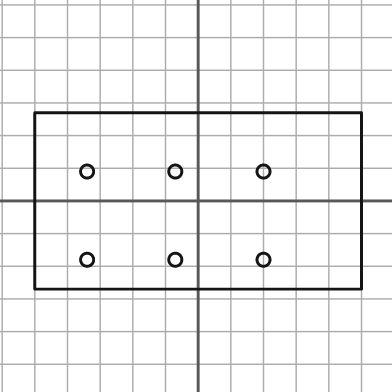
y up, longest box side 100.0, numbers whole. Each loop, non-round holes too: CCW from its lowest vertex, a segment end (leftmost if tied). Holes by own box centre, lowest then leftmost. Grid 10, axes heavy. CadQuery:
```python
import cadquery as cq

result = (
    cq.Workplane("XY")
    .moveTo(-50.0, -27.0)
    .lineTo(50.0, -27.0)
    .lineTo(50.0, 27.0)
    .lineTo(-50.0, 27.0)
    .close()
    .moveTo(-34.0, -18.0)
    .circle(2.0)
    .moveTo(-7.0, -18.0)
    .circle(2.0)
    .moveTo(20.0, -18.0)
    .circle(2.0)
    .moveTo(-34.0, 9.0)
    .circle(2.0)
    .moveTo(-7.0, 9.0)
    .circle(2.0)
    .moveTo(20.0, 9.0)
    .circle(2.0)
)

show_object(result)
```